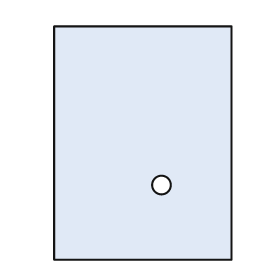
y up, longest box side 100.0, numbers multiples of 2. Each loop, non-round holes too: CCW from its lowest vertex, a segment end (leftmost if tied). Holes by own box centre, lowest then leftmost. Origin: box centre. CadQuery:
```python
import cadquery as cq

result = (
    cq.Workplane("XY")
    .moveTo(-38.0, -50.0)
    .lineTo(38.0, -50.0)
    .lineTo(38.0, 50.0)
    .lineTo(-38.0, 50.0)
    .close()
    .moveTo(8.0, -18.0)
    .circle(4.0)
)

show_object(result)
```